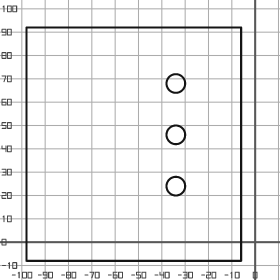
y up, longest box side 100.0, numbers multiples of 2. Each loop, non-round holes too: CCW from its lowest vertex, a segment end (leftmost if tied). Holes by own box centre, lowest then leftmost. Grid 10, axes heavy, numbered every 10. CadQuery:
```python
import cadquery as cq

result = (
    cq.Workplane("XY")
    .moveTo(-98.0, -8.0)
    .lineTo(-6.0, -8.0)
    .lineTo(-6.0, 92.0)
    .lineTo(-98.0, 92.0)
    .close()
    .moveTo(-34.0, 24.0)
    .circle(4.0)
    .moveTo(-34.0, 46.0)
    .circle(4.0)
    .moveTo(-34.0, 68.0)
    .circle(4.0)
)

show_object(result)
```